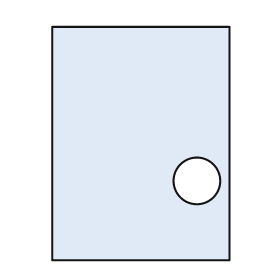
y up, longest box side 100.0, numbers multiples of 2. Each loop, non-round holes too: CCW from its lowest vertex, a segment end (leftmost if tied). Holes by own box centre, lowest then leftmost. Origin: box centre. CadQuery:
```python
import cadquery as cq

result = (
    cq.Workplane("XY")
    .moveTo(-38.0, -50.0)
    .lineTo(38.0, -50.0)
    .lineTo(38.0, 50.0)
    .lineTo(-38.0, 50.0)
    .close()
    .moveTo(24.0, -16.0)
    .circle(10.0)
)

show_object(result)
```